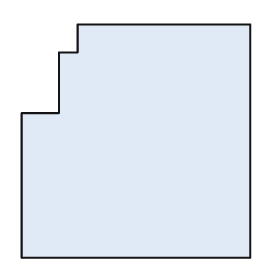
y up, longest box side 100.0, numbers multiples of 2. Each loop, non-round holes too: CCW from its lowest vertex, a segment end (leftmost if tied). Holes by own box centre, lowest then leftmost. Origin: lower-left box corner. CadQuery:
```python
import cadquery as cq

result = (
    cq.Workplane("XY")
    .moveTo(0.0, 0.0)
    .lineTo(98.0, 0.0)
    .lineTo(98.0, 100.0)
    .lineTo(24.0, 100.0)
    .lineTo(24.0, 88.0)
    .lineTo(16.0, 88.0)
    .lineTo(16.0, 62.0)
    .lineTo(0.0, 62.0)
    .close()
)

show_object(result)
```